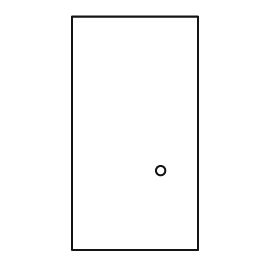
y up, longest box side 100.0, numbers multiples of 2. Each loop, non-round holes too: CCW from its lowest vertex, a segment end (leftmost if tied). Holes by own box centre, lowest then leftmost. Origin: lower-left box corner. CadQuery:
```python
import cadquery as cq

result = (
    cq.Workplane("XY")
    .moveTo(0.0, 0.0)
    .lineTo(54.0, 0.0)
    .lineTo(54.0, 100.0)
    .lineTo(0.0, 100.0)
    .close()
    .moveTo(38.0, 34.0)
    .circle(2.0)
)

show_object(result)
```